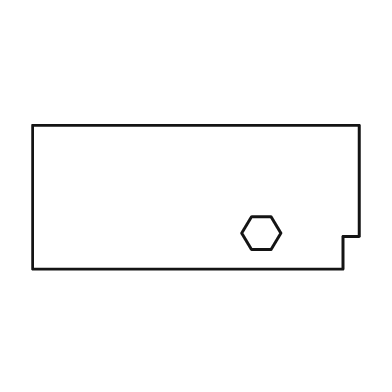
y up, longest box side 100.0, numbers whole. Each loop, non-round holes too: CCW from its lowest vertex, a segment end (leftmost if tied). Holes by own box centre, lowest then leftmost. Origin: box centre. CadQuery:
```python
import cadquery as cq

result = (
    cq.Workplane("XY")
    .moveTo(-50.0, -22.0)
    .lineTo(45.0, -22.0)
    .lineTo(45.0, -12.0)
    .lineTo(50.0, -12.0)
    .lineTo(50.0, 22.0)
    .lineTo(-50.0, 22.0)
    .close()
    .moveTo(17.0, -16.0)
    .lineTo(23.0, -16.0)
    .lineTo(26.0, -11.0)
    .lineTo(23.0, -6.0)
    .lineTo(17.0, -6.0)
    .lineTo(14.0, -11.0)
    .close()
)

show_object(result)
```